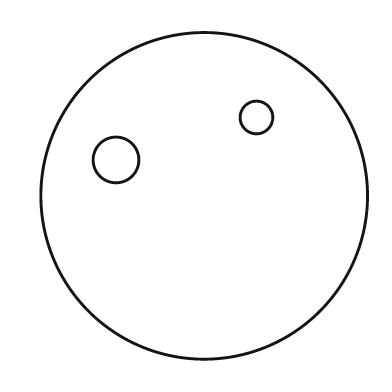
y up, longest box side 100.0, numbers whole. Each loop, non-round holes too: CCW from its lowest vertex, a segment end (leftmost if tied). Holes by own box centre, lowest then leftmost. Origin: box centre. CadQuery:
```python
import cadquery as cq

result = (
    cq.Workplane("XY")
    .moveTo(0.0, 0.0)
    .circle(50.0)
    .moveTo(-27.0, 11.0)
    .circle(7.0)
    .moveTo(16.0, 24.0)
    .circle(5.0)
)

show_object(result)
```